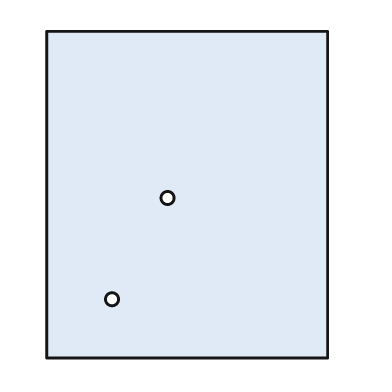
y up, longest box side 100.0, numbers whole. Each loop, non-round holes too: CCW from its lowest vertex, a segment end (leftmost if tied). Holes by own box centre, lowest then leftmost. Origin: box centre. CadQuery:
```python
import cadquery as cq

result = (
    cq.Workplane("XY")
    .moveTo(-43.0, -50.0)
    .lineTo(43.0, -50.0)
    .lineTo(43.0, 50.0)
    .lineTo(-43.0, 50.0)
    .close()
    .moveTo(-23.0, -32.0)
    .circle(2.0)
    .moveTo(-6.0, -1.0)
    .circle(2.0)
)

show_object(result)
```